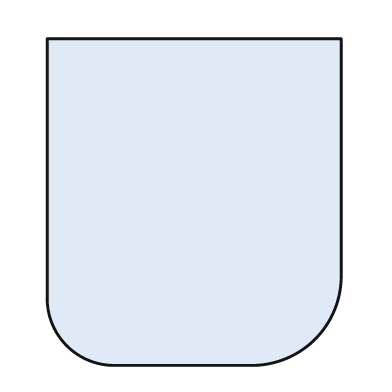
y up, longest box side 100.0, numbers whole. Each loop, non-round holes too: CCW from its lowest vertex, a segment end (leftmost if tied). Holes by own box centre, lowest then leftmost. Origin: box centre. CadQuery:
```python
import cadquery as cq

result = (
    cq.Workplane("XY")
    .moveTo(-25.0, -50.0)
    .lineTo(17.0, -50.0)
    .threePointArc((37.0, -42.0), (45.0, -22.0))
    .lineTo(45.0, 50.0)
    .lineTo(-45.0, 50.0)
    .lineTo(-45.0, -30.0)
    .threePointArc((-39.0, -44.0), (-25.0, -50.0))
    .close()
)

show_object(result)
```